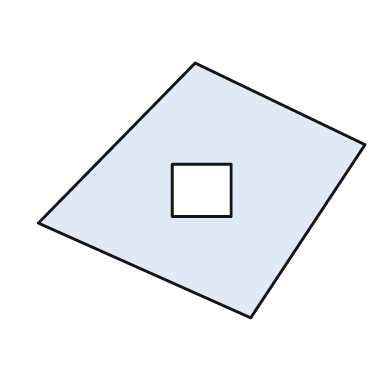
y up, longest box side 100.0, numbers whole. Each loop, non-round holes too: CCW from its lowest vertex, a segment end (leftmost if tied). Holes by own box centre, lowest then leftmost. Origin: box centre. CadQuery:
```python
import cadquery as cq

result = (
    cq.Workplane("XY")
    .moveTo(15.0, -39.0)
    .lineTo(50.0, 14.0)
    .lineTo(-2.0, 39.0)
    .lineTo(-50.0, -10.0)
    .close()
    .moveTo(-9.0, -8.0)
    .lineTo(9.0, -8.0)
    .lineTo(9.0, 8.0)
    .lineTo(-9.0, 8.0)
    .close()
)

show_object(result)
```